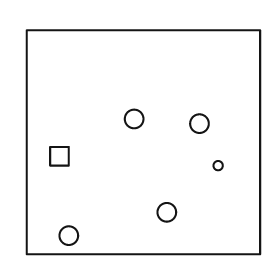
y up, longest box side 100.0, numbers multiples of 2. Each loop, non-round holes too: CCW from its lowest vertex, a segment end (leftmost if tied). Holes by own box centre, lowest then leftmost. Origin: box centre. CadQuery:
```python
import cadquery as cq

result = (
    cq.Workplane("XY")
    .moveTo(-50.0, -48.0)
    .lineTo(50.0, -48.0)
    .lineTo(50.0, 48.0)
    .lineTo(-50.0, 48.0)
    .close()
    .moveTo(-32.0, -40.0)
    .circle(4.0)
    .moveTo(10.0, -30.0)
    .circle(4.0)
    .moveTo(32.0, -10.0)
    .circle(2.0)
    .moveTo(-40.0, -10.0)
    .lineTo(-32.0, -10.0)
    .lineTo(-32.0, -2.0)
    .lineTo(-40.0, -2.0)
    .close()
    .moveTo(24.0, 8.0)
    .circle(4.0)
    .moveTo(-4.0, 10.0)
    .circle(4.0)
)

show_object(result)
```